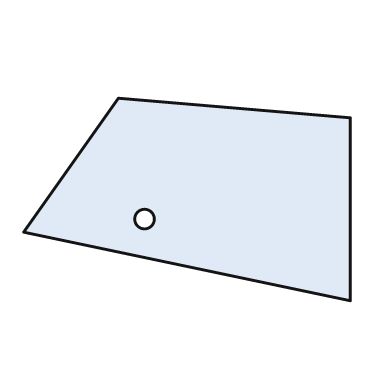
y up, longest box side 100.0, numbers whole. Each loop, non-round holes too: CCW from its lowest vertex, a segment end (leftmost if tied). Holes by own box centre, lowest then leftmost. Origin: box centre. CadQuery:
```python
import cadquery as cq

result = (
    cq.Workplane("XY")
    .moveTo(50.0, -31.0)
    .lineTo(50.0, 25.0)
    .lineTo(-21.0, 31.0)
    .lineTo(-50.0, -10.0)
    .close()
    .moveTo(-13.0, -6.0)
    .circle(3.0)
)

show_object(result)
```